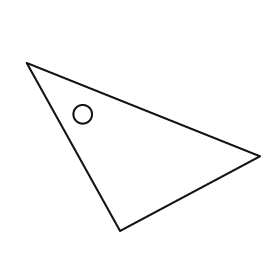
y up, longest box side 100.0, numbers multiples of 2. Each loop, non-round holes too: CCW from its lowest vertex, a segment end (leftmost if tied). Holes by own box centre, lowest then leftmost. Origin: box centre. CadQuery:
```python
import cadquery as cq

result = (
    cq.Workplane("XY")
    .moveTo(-10.0, -36.0)
    .lineTo(50.0, -4.0)
    .lineTo(-50.0, 36.0)
    .close()
    .moveTo(-26.0, 14.0)
    .circle(4.0)
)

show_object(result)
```